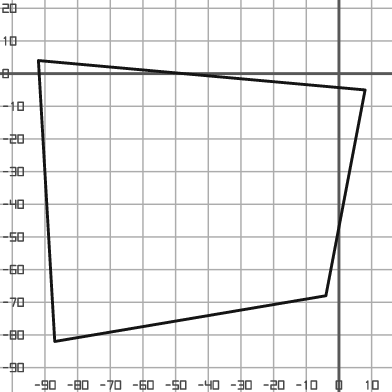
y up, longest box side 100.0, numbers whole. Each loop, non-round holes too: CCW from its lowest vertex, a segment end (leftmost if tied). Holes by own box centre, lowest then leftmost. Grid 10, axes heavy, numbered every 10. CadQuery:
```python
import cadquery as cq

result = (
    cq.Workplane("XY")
    .moveTo(-87.0, -82.0)
    .lineTo(-4.0, -68.0)
    .lineTo(8.0, -5.0)
    .lineTo(-92.0, 4.0)
    .close()
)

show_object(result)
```